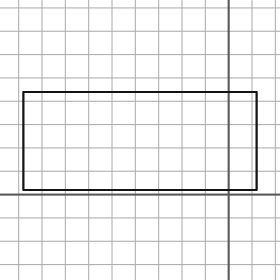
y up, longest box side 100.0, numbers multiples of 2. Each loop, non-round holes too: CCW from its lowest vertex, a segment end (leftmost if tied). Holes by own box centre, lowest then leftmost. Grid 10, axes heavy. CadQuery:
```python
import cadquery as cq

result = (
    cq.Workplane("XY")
    .moveTo(-88.0, 2.0)
    .lineTo(12.0, 2.0)
    .lineTo(12.0, 44.0)
    .lineTo(-88.0, 44.0)
    .close()
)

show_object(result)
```